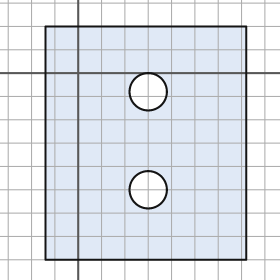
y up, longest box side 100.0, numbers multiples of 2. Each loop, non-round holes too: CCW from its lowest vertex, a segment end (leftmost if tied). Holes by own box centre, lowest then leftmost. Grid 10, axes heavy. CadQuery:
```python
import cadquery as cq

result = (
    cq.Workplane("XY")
    .moveTo(-14.0, -80.0)
    .lineTo(72.0, -80.0)
    .lineTo(72.0, 20.0)
    .lineTo(-14.0, 20.0)
    .close()
    .moveTo(30.0, -50.0)
    .circle(8.0)
    .moveTo(30.0, -8.0)
    .circle(8.0)
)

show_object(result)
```